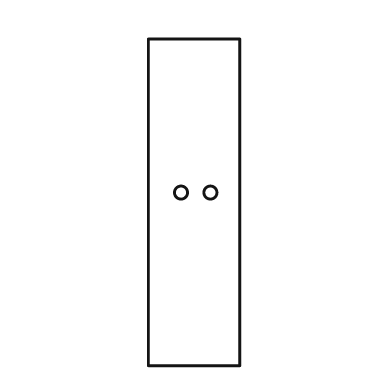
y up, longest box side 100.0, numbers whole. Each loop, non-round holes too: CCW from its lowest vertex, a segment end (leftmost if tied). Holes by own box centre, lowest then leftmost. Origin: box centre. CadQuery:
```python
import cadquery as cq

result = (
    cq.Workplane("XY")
    .moveTo(-14.0, -50.0)
    .lineTo(14.0, -50.0)
    .lineTo(14.0, 50.0)
    .lineTo(-14.0, 50.0)
    .close()
    .moveTo(-4.0, 3.0)
    .circle(2.0)
    .moveTo(5.0, 3.0)
    .circle(2.0)
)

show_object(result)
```